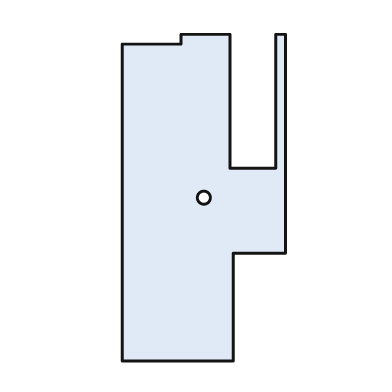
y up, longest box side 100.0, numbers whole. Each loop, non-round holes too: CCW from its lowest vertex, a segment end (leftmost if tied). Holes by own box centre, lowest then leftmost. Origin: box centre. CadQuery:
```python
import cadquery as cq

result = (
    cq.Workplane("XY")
    .moveTo(-25.0, -50.0)
    .lineTo(9.0, -50.0)
    .lineTo(9.0, -17.0)
    .lineTo(25.0, -17.0)
    .lineTo(25.0, 50.0)
    .lineTo(22.0, 50.0)
    .lineTo(22.0, 9.0)
    .lineTo(8.0, 9.0)
    .lineTo(8.0, 50.0)
    .lineTo(-7.0, 50.0)
    .lineTo(-7.0, 47.0)
    .lineTo(-25.0, 47.0)
    .close()
    .moveTo(0.0, 0.0)
    .circle(2.0)
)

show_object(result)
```